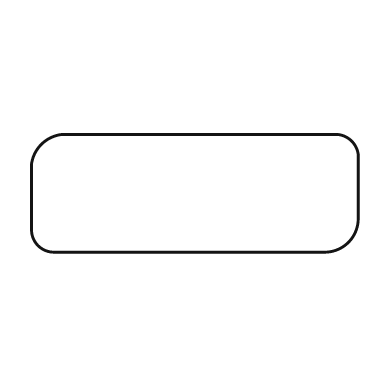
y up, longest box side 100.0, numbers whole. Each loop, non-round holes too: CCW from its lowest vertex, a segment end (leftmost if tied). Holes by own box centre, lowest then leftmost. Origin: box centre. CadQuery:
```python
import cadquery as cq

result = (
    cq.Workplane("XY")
    .moveTo(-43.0, -18.0)
    .lineTo(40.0, -18.0)
    .threePointArc((47.0, -15.0), (50.0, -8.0))
    .lineTo(50.0, 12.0)
    .threePointArc((48.0, 16.0), (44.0, 18.0))
    .lineTo(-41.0, 18.0)
    .threePointArc((-47.0, 15.0), (-50.0, 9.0))
    .lineTo(-50.0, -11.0)
    .threePointArc((-48.0, -16.0), (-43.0, -18.0))
    .close()
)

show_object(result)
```